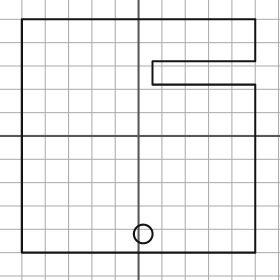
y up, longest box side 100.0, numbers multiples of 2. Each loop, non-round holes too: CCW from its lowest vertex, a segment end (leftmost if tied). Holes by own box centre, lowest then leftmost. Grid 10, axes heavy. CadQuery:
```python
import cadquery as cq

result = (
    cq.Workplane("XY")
    .moveTo(-50.0, -50.0)
    .lineTo(50.0, -50.0)
    .lineTo(50.0, 22.0)
    .lineTo(6.0, 22.0)
    .lineTo(6.0, 32.0)
    .lineTo(50.0, 32.0)
    .lineTo(50.0, 50.0)
    .lineTo(-50.0, 50.0)
    .close()
    .moveTo(2.0, -42.0)
    .circle(4.0)
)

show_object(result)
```